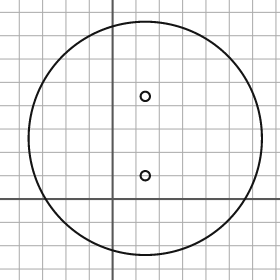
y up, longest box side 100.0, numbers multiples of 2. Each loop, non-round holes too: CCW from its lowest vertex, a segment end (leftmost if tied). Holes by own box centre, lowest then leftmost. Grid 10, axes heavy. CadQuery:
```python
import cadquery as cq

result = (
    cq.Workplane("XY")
    .moveTo(14.0, 26.0)
    .circle(50.0)
    .moveTo(14.0, 10.0)
    .circle(2.0)
    .moveTo(14.0, 44.0)
    .circle(2.0)
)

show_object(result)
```